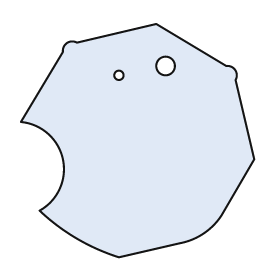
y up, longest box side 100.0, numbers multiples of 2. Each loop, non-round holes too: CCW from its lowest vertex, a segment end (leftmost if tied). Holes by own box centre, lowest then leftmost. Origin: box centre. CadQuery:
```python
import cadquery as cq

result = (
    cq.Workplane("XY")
    .moveTo(-8.0, -50.0)
    .lineTo(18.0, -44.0)
    .threePointArc((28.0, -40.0), (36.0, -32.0))
    .lineTo(50.0, -8.0)
    .lineTo(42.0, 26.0)
    .threePointArc((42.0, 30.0), (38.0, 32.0))
    .lineTo(8.0, 50.0)
    .lineTo(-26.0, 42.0)
    .threePointArc((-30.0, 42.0), (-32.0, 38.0))
    .lineTo(-50.0, 8.0)
    .threePointArc((-32.0, -8.0), (-42.0, -30.0))
    .threePointArc((-26.0, -42.0), (-8.0, -50.0))
    .close()
    .moveTo(-8.0, 28.0)
    .circle(2.0)
    .moveTo(12.0, 32.0)
    .circle(4.0)
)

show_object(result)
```